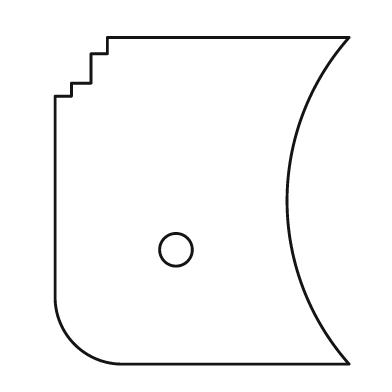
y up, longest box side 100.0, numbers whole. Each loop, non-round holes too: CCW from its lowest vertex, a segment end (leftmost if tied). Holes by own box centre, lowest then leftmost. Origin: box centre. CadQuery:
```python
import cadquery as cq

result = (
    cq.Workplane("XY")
    .moveTo(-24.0, -50.0)
    .lineTo(45.0, -50.0)
    .threePointArc((26.0, 0.0), (45.0, 50.0))
    .lineTo(-29.0, 50.0)
    .lineTo(-29.0, 45.0)
    .lineTo(-34.0, 45.0)
    .lineTo(-34.0, 36.0)
    .lineTo(-40.0, 36.0)
    .lineTo(-40.0, 32.0)
    .lineTo(-45.0, 32.0)
    .lineTo(-45.0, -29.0)
    .threePointArc((-39.0, -44.0), (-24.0, -50.0))
    .close()
    .moveTo(-8.0, -15.0)
    .circle(5.0)
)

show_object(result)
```